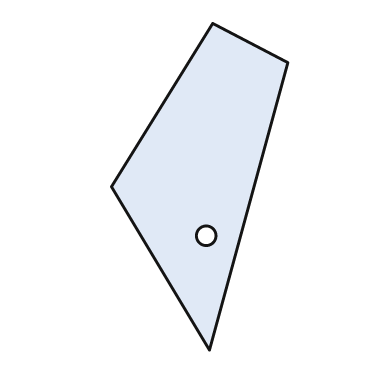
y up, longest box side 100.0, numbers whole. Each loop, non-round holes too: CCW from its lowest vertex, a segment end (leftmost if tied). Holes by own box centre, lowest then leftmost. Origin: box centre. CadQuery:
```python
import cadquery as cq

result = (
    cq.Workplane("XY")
    .moveTo(3.0, -50.0)
    .lineTo(27.0, 38.0)
    .lineTo(4.0, 50.0)
    .lineTo(-27.0, 0.0)
    .close()
    .moveTo(2.0, -15.0)
    .circle(3.0)
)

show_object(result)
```